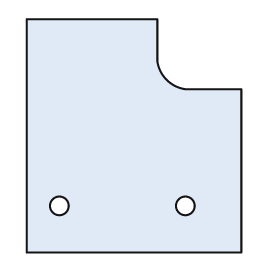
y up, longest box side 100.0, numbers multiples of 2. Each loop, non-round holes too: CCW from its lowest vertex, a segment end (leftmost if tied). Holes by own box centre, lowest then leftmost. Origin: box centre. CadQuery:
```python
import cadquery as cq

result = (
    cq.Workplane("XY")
    .moveTo(-46.0, -50.0)
    .lineTo(46.0, -50.0)
    .lineTo(46.0, 20.0)
    .lineTo(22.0, 20.0)
    .threePointArc((14.0, 24.0), (10.0, 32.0))
    .lineTo(10.0, 50.0)
    .lineTo(-46.0, 50.0)
    .close()
    .moveTo(-32.0, -30.0)
    .circle(4.0)
    .moveTo(22.0, -30.0)
    .circle(4.0)
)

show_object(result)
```